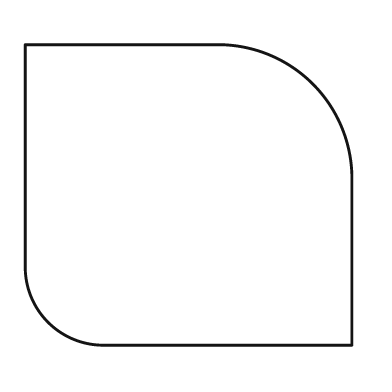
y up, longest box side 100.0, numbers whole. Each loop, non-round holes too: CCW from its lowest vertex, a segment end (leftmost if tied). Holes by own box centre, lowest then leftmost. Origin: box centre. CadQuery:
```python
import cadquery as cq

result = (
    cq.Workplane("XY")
    .moveTo(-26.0, -46.0)
    .lineTo(50.0, -46.0)
    .lineTo(50.0, 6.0)
    .threePointArc((38.0, 34.0), (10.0, 46.0))
    .lineTo(-50.0, 46.0)
    .lineTo(-50.0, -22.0)
    .threePointArc((-43.0, -39.0), (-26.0, -46.0))
    .close()
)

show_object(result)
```